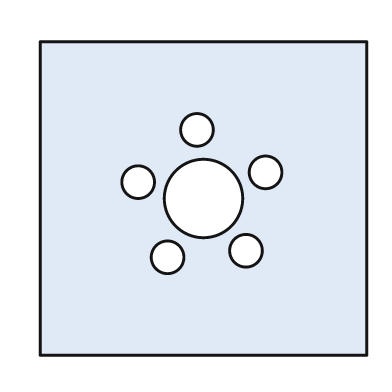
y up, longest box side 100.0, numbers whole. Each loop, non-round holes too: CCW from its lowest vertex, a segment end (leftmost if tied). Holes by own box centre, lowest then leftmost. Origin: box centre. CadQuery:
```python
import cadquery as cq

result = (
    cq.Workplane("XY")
    .moveTo(-50.0, -48.0)
    .lineTo(50.0, -48.0)
    .lineTo(50.0, 48.0)
    .lineTo(-50.0, 48.0)
    .close()
    .moveTo(-11.0, -18.0)
    .circle(5.0)
    .moveTo(13.0, -16.0)
    .circle(5.0)
    .moveTo(0.0, 0.0)
    .circle(12.0)
    .moveTo(-20.0, 5.0)
    .circle(5.0)
    .moveTo(19.0, 8.0)
    .circle(5.0)
    .moveTo(-2.0, 21.0)
    .circle(5.0)
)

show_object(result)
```